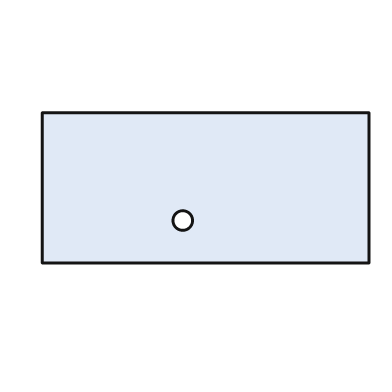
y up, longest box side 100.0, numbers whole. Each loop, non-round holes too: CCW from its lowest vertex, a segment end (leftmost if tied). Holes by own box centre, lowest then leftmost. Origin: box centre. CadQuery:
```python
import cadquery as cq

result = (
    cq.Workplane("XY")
    .moveTo(-50.0, -23.0)
    .lineTo(50.0, -23.0)
    .lineTo(50.0, 23.0)
    .lineTo(-50.0, 23.0)
    .close()
    .moveTo(-7.0, -10.0)
    .circle(3.0)
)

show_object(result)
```